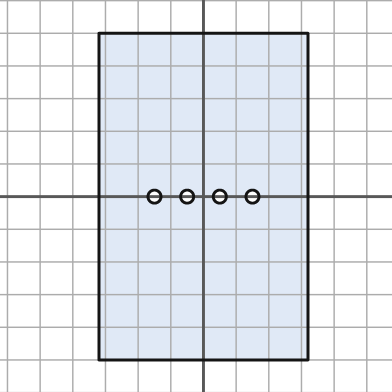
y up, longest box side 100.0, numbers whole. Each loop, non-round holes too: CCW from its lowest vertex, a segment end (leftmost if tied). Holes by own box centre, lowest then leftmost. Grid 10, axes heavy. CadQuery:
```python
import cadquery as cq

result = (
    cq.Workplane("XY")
    .moveTo(-32.0, -50.0)
    .lineTo(32.0, -50.0)
    .lineTo(32.0, 50.0)
    .lineTo(-32.0, 50.0)
    .close()
    .moveTo(-15.0, 0.0)
    .circle(2.0)
    .moveTo(-5.0, 0.0)
    .circle(2.0)
    .moveTo(5.0, 0.0)
    .circle(2.0)
    .moveTo(15.0, 0.0)
    .circle(2.0)
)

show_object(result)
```